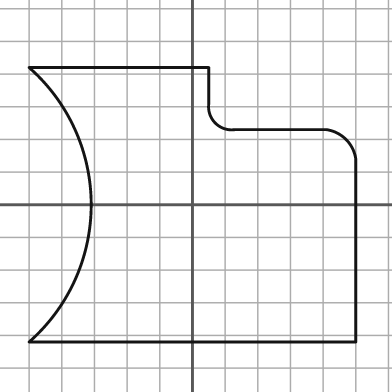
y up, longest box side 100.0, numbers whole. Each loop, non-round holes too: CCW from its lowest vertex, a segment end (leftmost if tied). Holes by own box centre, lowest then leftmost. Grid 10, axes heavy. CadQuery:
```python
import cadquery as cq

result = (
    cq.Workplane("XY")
    .moveTo(-50.0, -42.0)
    .lineTo(50.0, -42.0)
    .lineTo(50.0, 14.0)
    .threePointArc((47.0, 20.0), (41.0, 23.0))
    .lineTo(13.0, 23.0)
    .threePointArc((7.0, 25.0), (5.0, 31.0))
    .lineTo(5.0, 42.0)
    .lineTo(-50.0, 42.0)
    .threePointArc((-31.0, 0.0), (-50.0, -42.0))
    .close()
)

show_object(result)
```